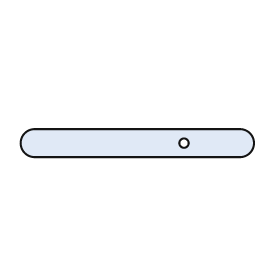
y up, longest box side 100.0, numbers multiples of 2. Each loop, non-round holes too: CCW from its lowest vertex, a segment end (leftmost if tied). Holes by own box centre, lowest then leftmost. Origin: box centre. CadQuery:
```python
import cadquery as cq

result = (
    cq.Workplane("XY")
    .moveTo(-44.0, -6.0)
    .lineTo(44.0, -6.0)
    .threePointArc((50.0, 0.0), (44.0, 6.0))
    .lineTo(-44.0, 6.0)
    .threePointArc((-50.0, 0.0), (-44.0, -6.0))
    .close()
    .moveTo(20.0, 0.0)
    .circle(2.0)
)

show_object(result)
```